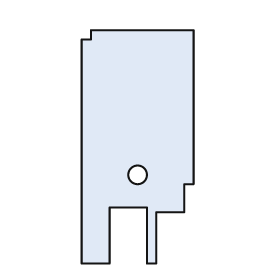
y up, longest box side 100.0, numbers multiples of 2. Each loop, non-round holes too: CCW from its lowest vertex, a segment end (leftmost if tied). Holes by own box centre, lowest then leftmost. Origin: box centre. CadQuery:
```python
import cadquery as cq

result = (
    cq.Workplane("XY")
    .moveTo(-24.0, -50.0)
    .lineTo(-12.0, -50.0)
    .lineTo(-12.0, -26.0)
    .lineTo(4.0, -26.0)
    .lineTo(4.0, -50.0)
    .lineTo(8.0, -50.0)
    .lineTo(8.0, -28.0)
    .lineTo(20.0, -28.0)
    .lineTo(20.0, -16.0)
    .lineTo(24.0, -16.0)
    .lineTo(24.0, 50.0)
    .lineTo(-20.0, 50.0)
    .lineTo(-20.0, 46.0)
    .lineTo(-24.0, 46.0)
    .close()
    .moveTo(0.0, -12.0)
    .circle(4.0)
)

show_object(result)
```